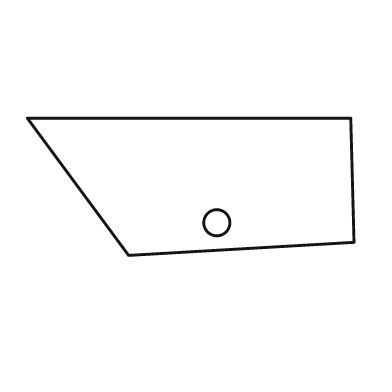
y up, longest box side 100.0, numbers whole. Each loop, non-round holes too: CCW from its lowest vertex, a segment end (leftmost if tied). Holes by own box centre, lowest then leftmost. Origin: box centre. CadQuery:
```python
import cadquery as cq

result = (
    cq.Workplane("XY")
    .moveTo(-19.0, -21.0)
    .lineTo(50.0, -17.0)
    .lineTo(49.0, 21.0)
    .lineTo(-50.0, 21.0)
    .close()
    .moveTo(8.0, -11.0)
    .circle(4.0)
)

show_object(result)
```